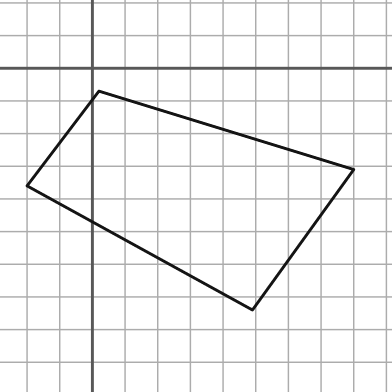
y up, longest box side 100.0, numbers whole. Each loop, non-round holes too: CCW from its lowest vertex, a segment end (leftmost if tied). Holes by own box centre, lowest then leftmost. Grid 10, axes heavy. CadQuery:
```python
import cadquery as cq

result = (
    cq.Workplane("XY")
    .moveTo(49.0, -74.0)
    .lineTo(80.0, -31.0)
    .lineTo(2.0, -7.0)
    .lineTo(-20.0, -36.0)
    .close()
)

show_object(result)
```